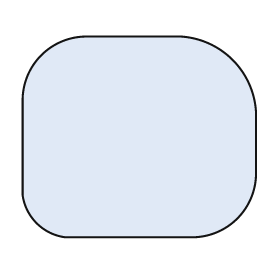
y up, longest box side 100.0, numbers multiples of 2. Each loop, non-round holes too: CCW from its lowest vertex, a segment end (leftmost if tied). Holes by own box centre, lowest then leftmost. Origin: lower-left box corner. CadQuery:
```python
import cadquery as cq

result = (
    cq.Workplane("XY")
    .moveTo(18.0, 0.0)
    .lineTo(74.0, 0.0)
    .threePointArc((92.0, 8.0), (100.0, 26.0))
    .lineTo(100.0, 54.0)
    .threePointArc((90.0, 76.0), (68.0, 86.0))
    .lineTo(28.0, 86.0)
    .threePointArc((8.0, 78.0), (0.0, 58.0))
    .lineTo(0.0, 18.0)
    .threePointArc((6.0, 6.0), (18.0, 0.0))
    .close()
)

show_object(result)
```